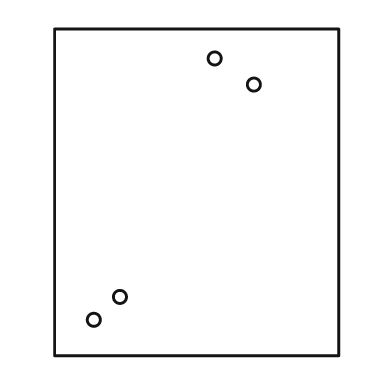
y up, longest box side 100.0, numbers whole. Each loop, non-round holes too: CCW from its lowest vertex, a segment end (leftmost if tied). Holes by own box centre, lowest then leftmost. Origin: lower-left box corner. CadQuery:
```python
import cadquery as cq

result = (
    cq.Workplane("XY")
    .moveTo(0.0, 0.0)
    .lineTo(87.0, 0.0)
    .lineTo(87.0, 100.0)
    .lineTo(0.0, 100.0)
    .close()
    .moveTo(12.0, 11.0)
    .circle(2.0)
    .moveTo(20.0, 18.0)
    .circle(2.0)
    .moveTo(61.0, 83.0)
    .circle(2.0)
    .moveTo(49.0, 91.0)
    .circle(2.0)
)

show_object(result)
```